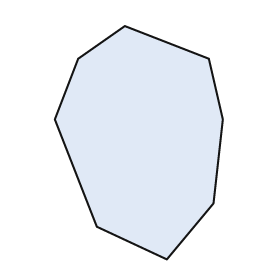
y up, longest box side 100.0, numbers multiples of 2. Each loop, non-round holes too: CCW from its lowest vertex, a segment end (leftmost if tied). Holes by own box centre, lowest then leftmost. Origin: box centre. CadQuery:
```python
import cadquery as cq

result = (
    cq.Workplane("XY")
    .moveTo(12.0, -50.0)
    .lineTo(32.0, -26.0)
    .lineTo(36.0, 10.0)
    .lineTo(30.0, 36.0)
    .lineTo(-6.0, 50.0)
    .lineTo(-26.0, 36.0)
    .lineTo(-36.0, 10.0)
    .lineTo(-18.0, -36.0)
    .close()
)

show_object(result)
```